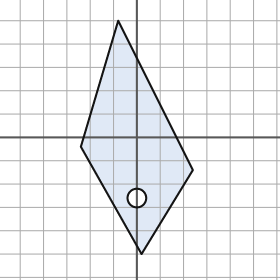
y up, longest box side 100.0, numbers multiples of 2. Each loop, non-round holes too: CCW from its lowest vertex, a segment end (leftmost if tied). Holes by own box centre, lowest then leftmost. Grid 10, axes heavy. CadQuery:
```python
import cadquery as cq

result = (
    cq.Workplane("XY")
    .moveTo(2.0, -50.0)
    .lineTo(24.0, -14.0)
    .lineTo(-8.0, 50.0)
    .lineTo(-24.0, -4.0)
    .close()
    .moveTo(0.0, -26.0)
    .circle(4.0)
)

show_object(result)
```